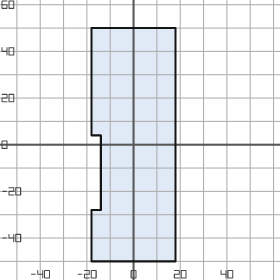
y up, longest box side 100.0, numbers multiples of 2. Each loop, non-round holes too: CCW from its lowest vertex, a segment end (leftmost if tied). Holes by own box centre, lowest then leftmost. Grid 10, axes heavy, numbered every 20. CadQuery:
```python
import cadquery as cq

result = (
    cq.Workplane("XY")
    .moveTo(-18.0, -50.0)
    .lineTo(18.0, -50.0)
    .lineTo(18.0, 50.0)
    .lineTo(-18.0, 50.0)
    .lineTo(-18.0, 4.0)
    .lineTo(-14.0, 4.0)
    .lineTo(-14.0, -28.0)
    .lineTo(-18.0, -28.0)
    .close()
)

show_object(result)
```